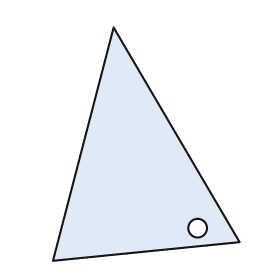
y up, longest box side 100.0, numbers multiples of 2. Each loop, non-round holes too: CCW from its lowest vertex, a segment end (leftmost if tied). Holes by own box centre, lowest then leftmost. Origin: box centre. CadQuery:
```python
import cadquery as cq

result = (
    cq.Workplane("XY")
    .moveTo(-40.0, -50.0)
    .lineTo(40.0, -42.0)
    .lineTo(-14.0, 50.0)
    .close()
    .moveTo(22.0, -36.0)
    .circle(4.0)
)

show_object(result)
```